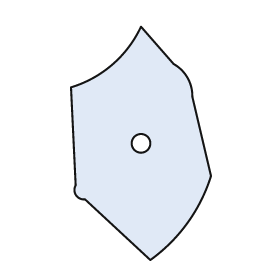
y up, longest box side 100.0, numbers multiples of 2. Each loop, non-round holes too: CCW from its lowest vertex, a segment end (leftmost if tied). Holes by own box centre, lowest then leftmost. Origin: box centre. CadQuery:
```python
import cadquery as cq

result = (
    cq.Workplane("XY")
    .moveTo(4.0, -50.0)
    .threePointArc((20.0, -34.0), (30.0, -14.0))
    .lineTo(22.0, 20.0)
    .threePointArc((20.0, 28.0), (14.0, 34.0))
    .lineTo(0.0, 50.0)
    .threePointArc((-12.0, 34.0), (-30.0, 24.0))
    .lineTo(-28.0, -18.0)
    .threePointArc((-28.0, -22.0), (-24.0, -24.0))
    .close()
    .moveTo(0.0, 0.0)
    .circle(4.0)
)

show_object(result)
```